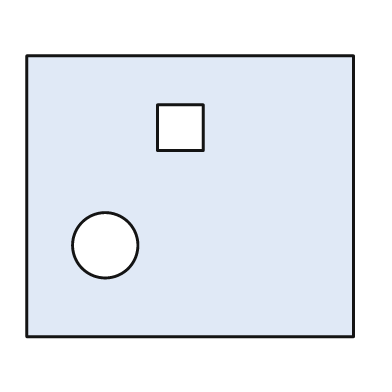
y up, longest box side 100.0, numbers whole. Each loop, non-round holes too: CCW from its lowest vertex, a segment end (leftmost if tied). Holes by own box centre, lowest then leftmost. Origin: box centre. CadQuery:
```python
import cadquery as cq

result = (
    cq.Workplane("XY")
    .moveTo(-50.0, -43.0)
    .lineTo(50.0, -43.0)
    .lineTo(50.0, 43.0)
    .lineTo(-50.0, 43.0)
    .close()
    .moveTo(-26.0, -15.0)
    .circle(10.0)
    .moveTo(-10.0, 14.0)
    .lineTo(4.0, 14.0)
    .lineTo(4.0, 28.0)
    .lineTo(-10.0, 28.0)
    .close()
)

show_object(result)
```